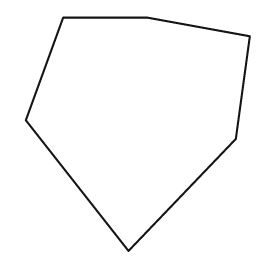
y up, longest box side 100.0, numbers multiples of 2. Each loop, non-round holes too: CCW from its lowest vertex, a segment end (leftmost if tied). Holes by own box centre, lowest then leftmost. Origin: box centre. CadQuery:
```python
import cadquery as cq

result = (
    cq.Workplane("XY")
    .moveTo(-4.0, -50.0)
    .lineTo(42.0, -2.0)
    .lineTo(48.0, 42.0)
    .lineTo(4.0, 50.0)
    .lineTo(-32.0, 50.0)
    .lineTo(-48.0, 6.0)
    .close()
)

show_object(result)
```